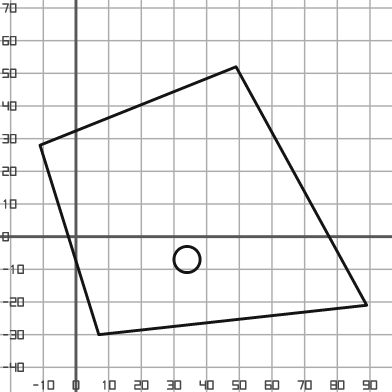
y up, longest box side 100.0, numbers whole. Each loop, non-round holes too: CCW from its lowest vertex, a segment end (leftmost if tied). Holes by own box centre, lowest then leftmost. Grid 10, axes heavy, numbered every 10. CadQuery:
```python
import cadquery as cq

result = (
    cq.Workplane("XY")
    .moveTo(7.0, -30.0)
    .lineTo(89.0, -21.0)
    .lineTo(49.0, 52.0)
    .lineTo(-11.0, 28.0)
    .close()
    .moveTo(34.0, -7.0)
    .circle(4.0)
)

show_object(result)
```